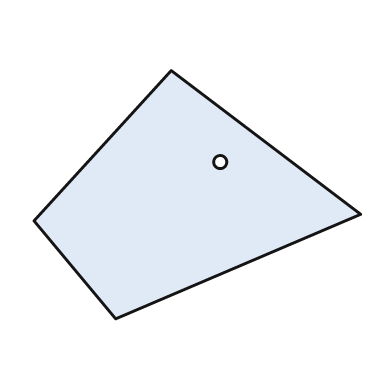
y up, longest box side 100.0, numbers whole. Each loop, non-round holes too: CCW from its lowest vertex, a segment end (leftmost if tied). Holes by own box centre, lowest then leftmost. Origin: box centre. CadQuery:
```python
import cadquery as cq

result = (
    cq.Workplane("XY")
    .moveTo(-25.0, -38.0)
    .lineTo(50.0, -6.0)
    .lineTo(-8.0, 38.0)
    .lineTo(-50.0, -8.0)
    .close()
    .moveTo(7.0, 10.0)
    .circle(2.0)
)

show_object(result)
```